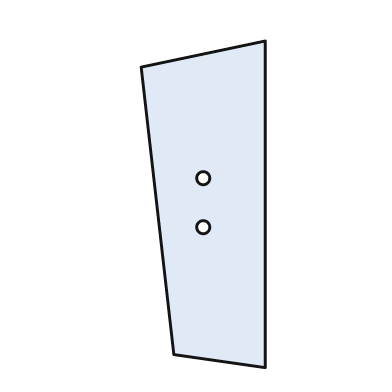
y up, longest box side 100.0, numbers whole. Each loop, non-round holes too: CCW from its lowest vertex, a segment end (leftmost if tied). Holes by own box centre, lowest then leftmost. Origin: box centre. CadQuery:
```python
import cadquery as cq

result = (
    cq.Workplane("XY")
    .moveTo(19.0, -50.0)
    .lineTo(19.0, 50.0)
    .lineTo(-19.0, 42.0)
    .lineTo(-9.0, -46.0)
    .close()
    .moveTo(0.0, -7.0)
    .circle(2.0)
    .moveTo(0.0, 8.0)
    .circle(2.0)
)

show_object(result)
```